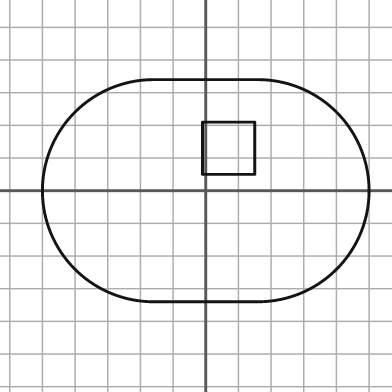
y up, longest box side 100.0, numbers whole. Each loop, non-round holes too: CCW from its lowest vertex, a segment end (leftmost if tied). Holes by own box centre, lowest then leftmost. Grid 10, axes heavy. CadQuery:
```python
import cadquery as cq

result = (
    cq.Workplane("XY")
    .moveTo(-16.0, -34.0)
    .lineTo(16.0, -34.0)
    .threePointArc((50.0, 0.0), (16.0, 34.0))
    .lineTo(-16.0, 34.0)
    .threePointArc((-50.0, 0.0), (-16.0, -34.0))
    .close()
    .moveTo(-1.0, 5.0)
    .lineTo(15.0, 5.0)
    .lineTo(15.0, 21.0)
    .lineTo(-1.0, 21.0)
    .close()
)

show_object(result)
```